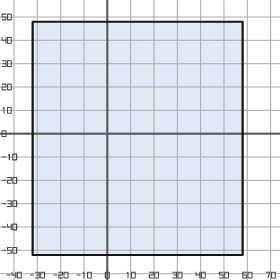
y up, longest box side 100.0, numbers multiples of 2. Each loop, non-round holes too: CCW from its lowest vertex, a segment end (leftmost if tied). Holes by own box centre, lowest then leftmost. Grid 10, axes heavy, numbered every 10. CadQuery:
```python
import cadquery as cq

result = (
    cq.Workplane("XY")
    .moveTo(-32.0, -52.0)
    .lineTo(58.0, -52.0)
    .lineTo(58.0, 48.0)
    .lineTo(-32.0, 48.0)
    .close()
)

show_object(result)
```